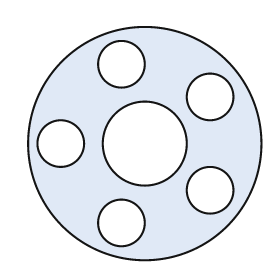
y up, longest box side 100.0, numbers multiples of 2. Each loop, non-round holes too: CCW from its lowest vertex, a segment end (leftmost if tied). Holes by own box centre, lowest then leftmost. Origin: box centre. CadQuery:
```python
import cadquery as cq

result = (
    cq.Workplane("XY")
    .moveTo(0.0, 0.0)
    .circle(50.0)
    .moveTo(-10.0, -34.0)
    .circle(10.0)
    .moveTo(28.0, -20.0)
    .circle(10.0)
    .moveTo(-36.0, 0.0)
    .circle(10.0)
    .moveTo(0.0, 0.0)
    .circle(18.0)
    .moveTo(28.0, 20.0)
    .circle(10.0)
    .moveTo(-10.0, 34.0)
    .circle(10.0)
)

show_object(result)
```